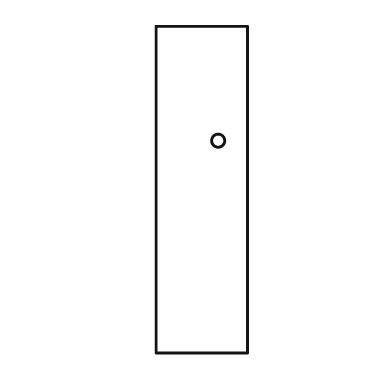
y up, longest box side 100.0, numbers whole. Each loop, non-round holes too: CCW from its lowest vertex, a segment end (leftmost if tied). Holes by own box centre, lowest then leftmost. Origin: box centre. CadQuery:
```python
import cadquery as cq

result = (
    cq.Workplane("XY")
    .moveTo(-14.0, -50.0)
    .lineTo(14.0, -50.0)
    .lineTo(14.0, 50.0)
    .lineTo(-14.0, 50.0)
    .close()
    .moveTo(5.0, 15.0)
    .circle(2.0)
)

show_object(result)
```